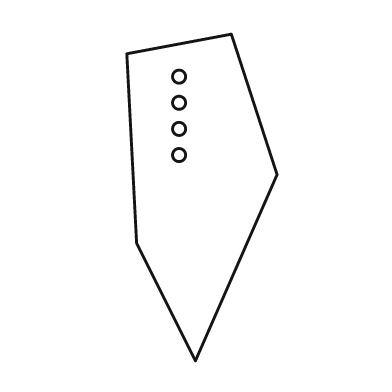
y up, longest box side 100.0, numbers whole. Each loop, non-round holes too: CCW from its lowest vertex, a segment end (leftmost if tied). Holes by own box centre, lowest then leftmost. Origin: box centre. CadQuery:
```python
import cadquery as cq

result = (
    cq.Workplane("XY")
    .moveTo(-2.0, -50.0)
    .lineTo(23.0, 7.0)
    .lineTo(9.0, 50.0)
    .lineTo(-23.0, 44.0)
    .lineTo(-20.0, -14.0)
    .close()
    .moveTo(-7.0, 13.0)
    .circle(2.0)
    .moveTo(-7.0, 21.0)
    .circle(2.0)
    .moveTo(-7.0, 29.0)
    .circle(2.0)
    .moveTo(-7.0, 37.0)
    .circle(2.0)
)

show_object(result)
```